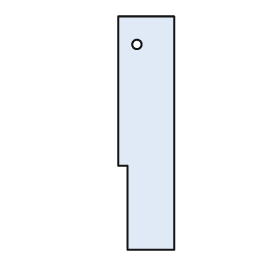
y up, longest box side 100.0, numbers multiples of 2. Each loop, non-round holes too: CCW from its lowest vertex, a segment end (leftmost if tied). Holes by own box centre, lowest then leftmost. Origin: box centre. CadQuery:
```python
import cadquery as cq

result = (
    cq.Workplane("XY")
    .moveTo(-8.0, -50.0)
    .lineTo(12.0, -50.0)
    .lineTo(12.0, 50.0)
    .lineTo(-12.0, 50.0)
    .lineTo(-12.0, -14.0)
    .lineTo(-8.0, -14.0)
    .close()
    .moveTo(-4.0, 38.0)
    .circle(2.0)
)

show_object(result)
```